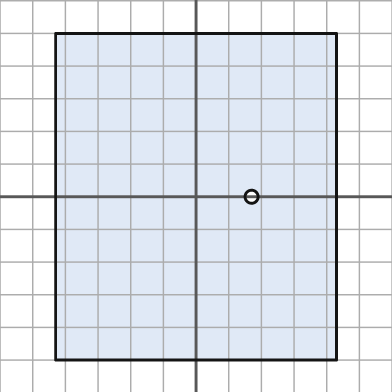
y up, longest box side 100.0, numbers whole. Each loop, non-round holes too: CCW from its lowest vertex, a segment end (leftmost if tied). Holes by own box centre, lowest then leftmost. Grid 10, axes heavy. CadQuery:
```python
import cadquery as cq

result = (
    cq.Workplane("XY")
    .moveTo(-43.0, -50.0)
    .lineTo(43.0, -50.0)
    .lineTo(43.0, 50.0)
    .lineTo(-43.0, 50.0)
    .close()
    .moveTo(17.0, 0.0)
    .circle(2.0)
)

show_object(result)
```